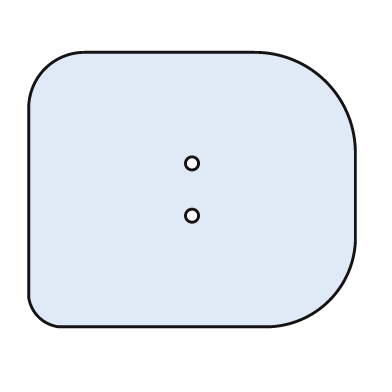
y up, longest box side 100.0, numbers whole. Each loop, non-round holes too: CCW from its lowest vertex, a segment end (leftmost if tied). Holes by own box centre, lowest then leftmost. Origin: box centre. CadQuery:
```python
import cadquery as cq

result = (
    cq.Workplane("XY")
    .moveTo(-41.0, -42.0)
    .lineTo(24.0, -42.0)
    .threePointArc((42.0, -34.0), (50.0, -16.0))
    .lineTo(50.0, 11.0)
    .threePointArc((41.0, 33.0), (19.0, 42.0))
    .lineTo(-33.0, 42.0)
    .threePointArc((-45.0, 37.0), (-50.0, 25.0))
    .lineTo(-50.0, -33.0)
    .threePointArc((-47.0, -39.0), (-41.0, -42.0))
    .close()
    .moveTo(0.0, -8.0)
    .circle(2.0)
    .moveTo(0.0, 8.0)
    .circle(2.0)
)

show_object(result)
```